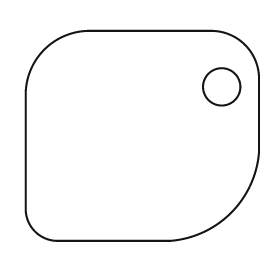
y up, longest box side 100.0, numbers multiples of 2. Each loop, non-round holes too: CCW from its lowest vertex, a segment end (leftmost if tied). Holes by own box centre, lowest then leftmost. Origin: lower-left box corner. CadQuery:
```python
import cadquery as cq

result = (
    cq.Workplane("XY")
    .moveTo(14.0, 0.0)
    .lineTo(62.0, 0.0)
    .threePointArc((88.0, 12.0), (100.0, 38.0))
    .lineTo(100.0, 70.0)
    .threePointArc((94.0, 84.0), (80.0, 90.0))
    .lineTo(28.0, 90.0)
    .threePointArc((8.0, 82.0), (0.0, 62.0))
    .lineTo(0.0, 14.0)
    .threePointArc((4.0, 4.0), (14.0, 0.0))
    .close()
    .moveTo(84.0, 66.0)
    .circle(8.0)
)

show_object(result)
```